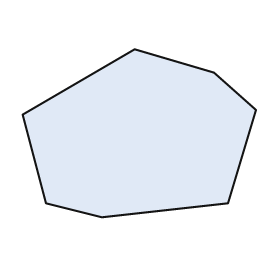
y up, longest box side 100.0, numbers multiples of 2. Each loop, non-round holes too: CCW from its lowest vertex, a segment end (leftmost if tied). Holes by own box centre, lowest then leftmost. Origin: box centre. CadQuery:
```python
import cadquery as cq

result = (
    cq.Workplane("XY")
    .moveTo(-16.0, -36.0)
    .lineTo(38.0, -30.0)
    .lineTo(50.0, 10.0)
    .lineTo(32.0, 26.0)
    .lineTo(-2.0, 36.0)
    .lineTo(-50.0, 8.0)
    .lineTo(-40.0, -30.0)
    .close()
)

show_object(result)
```